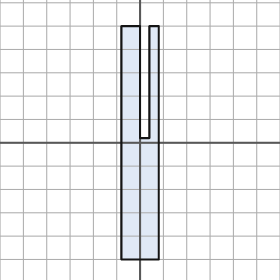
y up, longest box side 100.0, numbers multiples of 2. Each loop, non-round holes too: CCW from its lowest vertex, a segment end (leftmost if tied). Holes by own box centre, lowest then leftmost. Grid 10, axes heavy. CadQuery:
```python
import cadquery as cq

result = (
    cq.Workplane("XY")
    .moveTo(-8.0, -50.0)
    .lineTo(8.0, -50.0)
    .lineTo(8.0, 50.0)
    .lineTo(4.0, 50.0)
    .lineTo(4.0, 2.0)
    .lineTo(0.0, 2.0)
    .lineTo(0.0, 50.0)
    .lineTo(-8.0, 50.0)
    .close()
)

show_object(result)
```